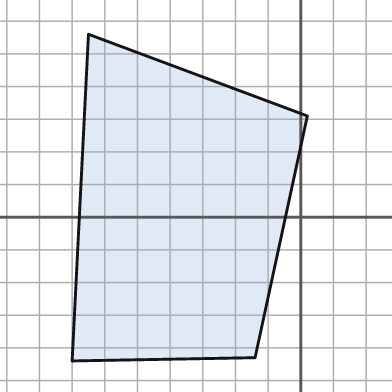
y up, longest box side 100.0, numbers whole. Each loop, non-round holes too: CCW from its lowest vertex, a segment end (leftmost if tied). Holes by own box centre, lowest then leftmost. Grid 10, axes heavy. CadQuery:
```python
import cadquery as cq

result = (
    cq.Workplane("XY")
    .moveTo(-70.0, -44.0)
    .lineTo(-14.0, -43.0)
    .lineTo(2.0, 31.0)
    .lineTo(-65.0, 56.0)
    .close()
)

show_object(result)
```